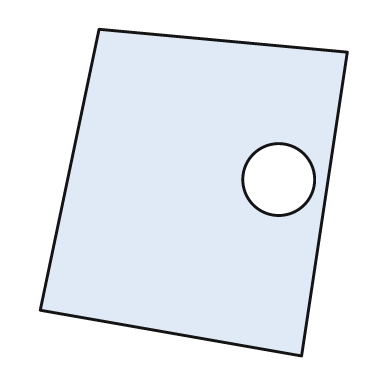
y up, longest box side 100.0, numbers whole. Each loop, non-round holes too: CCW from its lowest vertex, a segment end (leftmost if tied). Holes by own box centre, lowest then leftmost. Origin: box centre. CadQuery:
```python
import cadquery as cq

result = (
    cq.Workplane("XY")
    .moveTo(33.0, -50.0)
    .lineTo(47.0, 43.0)
    .lineTo(-29.0, 50.0)
    .lineTo(-47.0, -36.0)
    .close()
    .moveTo(26.0, 4.0)
    .circle(11.0)
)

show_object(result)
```